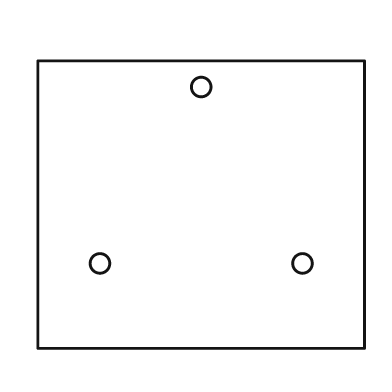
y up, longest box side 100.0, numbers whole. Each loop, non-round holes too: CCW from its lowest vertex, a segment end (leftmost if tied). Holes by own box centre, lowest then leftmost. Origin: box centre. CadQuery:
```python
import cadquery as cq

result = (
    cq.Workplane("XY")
    .moveTo(-50.0, -44.0)
    .lineTo(50.0, -44.0)
    .lineTo(50.0, 44.0)
    .lineTo(-50.0, 44.0)
    .close()
    .moveTo(-31.0, -18.0)
    .circle(3.0)
    .moveTo(31.0, -18.0)
    .circle(3.0)
    .moveTo(0.0, 36.0)
    .circle(3.0)
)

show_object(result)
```